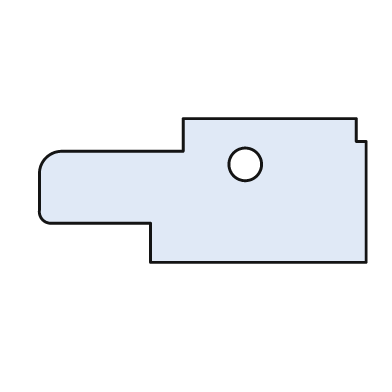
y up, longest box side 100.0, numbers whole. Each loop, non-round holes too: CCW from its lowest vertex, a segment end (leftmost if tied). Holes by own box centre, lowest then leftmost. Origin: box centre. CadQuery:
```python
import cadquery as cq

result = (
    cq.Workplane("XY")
    .moveTo(-16.0, -22.0)
    .lineTo(50.0, -22.0)
    .lineTo(50.0, 15.0)
    .lineTo(47.0, 15.0)
    .lineTo(47.0, 22.0)
    .lineTo(-6.0, 22.0)
    .lineTo(-6.0, 12.0)
    .lineTo(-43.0, 12.0)
    .threePointArc((-48.0, 10.0), (-50.0, 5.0))
    .lineTo(-50.0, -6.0)
    .threePointArc((-49.0, -9.0), (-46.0, -10.0))
    .lineTo(-16.0, -10.0)
    .close()
    .moveTo(13.0, 8.0)
    .circle(5.0)
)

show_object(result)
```